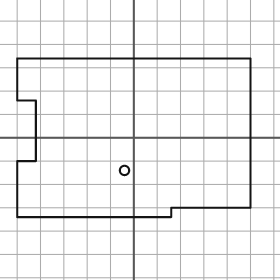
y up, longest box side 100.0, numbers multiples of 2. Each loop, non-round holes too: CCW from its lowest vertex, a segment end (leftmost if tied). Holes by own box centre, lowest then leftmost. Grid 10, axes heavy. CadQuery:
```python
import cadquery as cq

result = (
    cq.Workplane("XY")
    .moveTo(-50.0, -34.0)
    .lineTo(16.0, -34.0)
    .lineTo(16.0, -30.0)
    .lineTo(50.0, -30.0)
    .lineTo(50.0, 34.0)
    .lineTo(-50.0, 34.0)
    .lineTo(-50.0, 16.0)
    .lineTo(-42.0, 16.0)
    .lineTo(-42.0, -10.0)
    .lineTo(-50.0, -10.0)
    .close()
    .moveTo(-4.0, -14.0)
    .circle(2.0)
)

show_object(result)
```